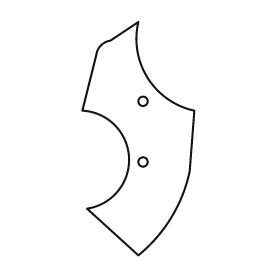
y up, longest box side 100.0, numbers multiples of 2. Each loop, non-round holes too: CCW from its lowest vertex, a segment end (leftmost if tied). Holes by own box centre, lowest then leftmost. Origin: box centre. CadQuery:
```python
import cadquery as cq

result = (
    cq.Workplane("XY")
    .moveTo(0.0, -50.0)
    .threePointArc((14.0, -34.0), (22.0, -14.0))
    .lineTo(24.0, 12.0)
    .threePointArc((4.0, 26.0), (0.0, 50.0))
    .lineTo(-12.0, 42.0)
    .threePointArc((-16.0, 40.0), (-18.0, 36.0))
    .lineTo(-24.0, 12.0)
    .threePointArc((-4.0, -8.0), (-22.0, -30.0))
    .close()
    .moveTo(2.0, -10.0)
    .circle(2.0)
    .moveTo(2.0, 16.0)
    .circle(2.0)
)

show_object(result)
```